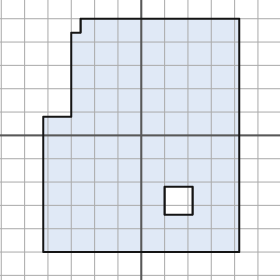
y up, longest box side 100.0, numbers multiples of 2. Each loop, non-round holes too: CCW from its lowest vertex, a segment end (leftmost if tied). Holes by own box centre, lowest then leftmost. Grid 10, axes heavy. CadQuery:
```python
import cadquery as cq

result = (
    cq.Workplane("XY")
    .moveTo(-42.0, -50.0)
    .lineTo(42.0, -50.0)
    .lineTo(42.0, 50.0)
    .lineTo(-26.0, 50.0)
    .lineTo(-26.0, 44.0)
    .lineTo(-30.0, 44.0)
    .lineTo(-30.0, 8.0)
    .lineTo(-42.0, 8.0)
    .close()
    .moveTo(10.0, -34.0)
    .lineTo(22.0, -34.0)
    .lineTo(22.0, -22.0)
    .lineTo(10.0, -22.0)
    .close()
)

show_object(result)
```